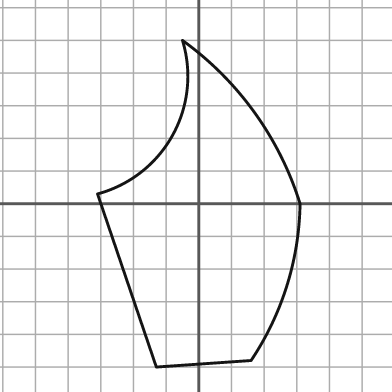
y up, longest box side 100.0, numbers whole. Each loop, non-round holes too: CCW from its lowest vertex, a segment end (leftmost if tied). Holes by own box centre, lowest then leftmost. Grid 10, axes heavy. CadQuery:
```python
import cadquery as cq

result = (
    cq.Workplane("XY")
    .moveTo(-13.0, -50.0)
    .lineTo(16.0, -48.0)
    .threePointArc((27.0, -25.0), (31.0, 0.0))
    .threePointArc((17.0, 28.0), (-5.0, 50.0))
    .threePointArc((-8.0, 21.0), (-31.0, 3.0))
    .close()
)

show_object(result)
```